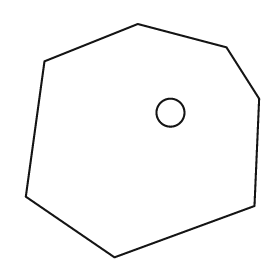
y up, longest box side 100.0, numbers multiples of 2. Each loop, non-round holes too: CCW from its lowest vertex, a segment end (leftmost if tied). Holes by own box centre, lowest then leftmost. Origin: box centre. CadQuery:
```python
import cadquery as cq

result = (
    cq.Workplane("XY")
    .moveTo(-12.0, -50.0)
    .lineTo(48.0, -28.0)
    .lineTo(50.0, 18.0)
    .lineTo(36.0, 40.0)
    .lineTo(-2.0, 50.0)
    .lineTo(-42.0, 34.0)
    .lineTo(-50.0, -24.0)
    .close()
    .moveTo(12.0, 12.0)
    .circle(6.0)
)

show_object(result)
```